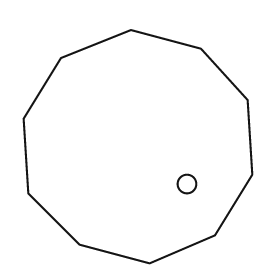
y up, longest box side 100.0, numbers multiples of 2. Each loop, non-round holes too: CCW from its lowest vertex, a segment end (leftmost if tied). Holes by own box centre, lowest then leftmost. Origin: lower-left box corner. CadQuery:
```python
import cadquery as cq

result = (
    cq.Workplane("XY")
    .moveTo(54.0, 0.0)
    .lineTo(82.0, 12.0)
    .lineTo(98.0, 38.0)
    .lineTo(96.0, 70.0)
    .lineTo(76.0, 92.0)
    .lineTo(46.0, 100.0)
    .lineTo(16.0, 88.0)
    .lineTo(0.0, 62.0)
    .lineTo(2.0, 30.0)
    .lineTo(24.0, 8.0)
    .close()
    .moveTo(70.0, 34.0)
    .circle(4.0)
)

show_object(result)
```